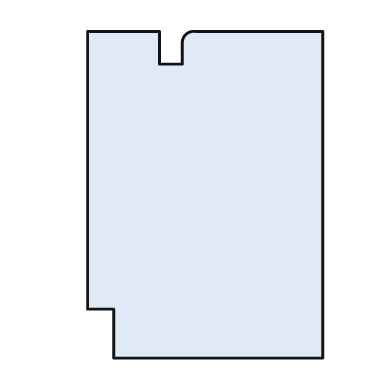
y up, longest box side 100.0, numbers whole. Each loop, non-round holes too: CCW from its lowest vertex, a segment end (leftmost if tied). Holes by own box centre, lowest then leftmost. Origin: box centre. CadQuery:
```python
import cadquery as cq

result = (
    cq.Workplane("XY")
    .moveTo(-28.0, -50.0)
    .lineTo(36.0, -50.0)
    .lineTo(36.0, 50.0)
    .lineTo(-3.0, 50.0)
    .threePointArc((-6.0, 49.0), (-7.0, 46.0))
    .lineTo(-7.0, 40.0)
    .lineTo(-14.0, 40.0)
    .lineTo(-14.0, 50.0)
    .lineTo(-36.0, 50.0)
    .lineTo(-36.0, -35.0)
    .lineTo(-28.0, -35.0)
    .close()
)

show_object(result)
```